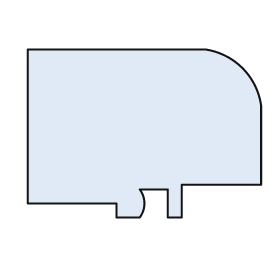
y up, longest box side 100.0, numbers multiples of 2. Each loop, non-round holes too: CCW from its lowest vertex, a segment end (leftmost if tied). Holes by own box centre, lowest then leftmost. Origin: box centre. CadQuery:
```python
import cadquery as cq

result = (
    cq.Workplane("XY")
    .moveTo(-12.0, -36.0)
    .lineTo(-2.0, -36.0)
    .threePointArc((0.0, -30.0), (-2.0, -24.0))
    .lineTo(10.0, -24.0)
    .lineTo(10.0, -36.0)
    .lineTo(16.0, -36.0)
    .lineTo(16.0, -22.0)
    .lineTo(50.0, -22.0)
    .lineTo(50.0, 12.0)
    .threePointArc((42.0, 28.0), (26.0, 36.0))
    .lineTo(-50.0, 36.0)
    .lineTo(-50.0, -30.0)
    .lineTo(-12.0, -30.0)
    .close()
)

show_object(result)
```